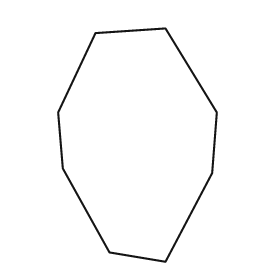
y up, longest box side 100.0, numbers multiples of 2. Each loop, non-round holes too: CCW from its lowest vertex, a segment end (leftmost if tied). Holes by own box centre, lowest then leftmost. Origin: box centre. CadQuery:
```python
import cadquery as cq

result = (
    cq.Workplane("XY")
    .moveTo(12.0, -50.0)
    .lineTo(32.0, -12.0)
    .lineTo(34.0, 14.0)
    .lineTo(12.0, 50.0)
    .lineTo(-18.0, 48.0)
    .lineTo(-34.0, 14.0)
    .lineTo(-32.0, -10.0)
    .lineTo(-12.0, -46.0)
    .close()
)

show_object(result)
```